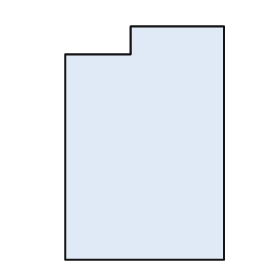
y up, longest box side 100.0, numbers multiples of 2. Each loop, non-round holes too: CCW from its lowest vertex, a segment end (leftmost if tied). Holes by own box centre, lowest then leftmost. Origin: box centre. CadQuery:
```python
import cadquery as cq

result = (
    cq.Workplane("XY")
    .moveTo(-34.0, -50.0)
    .lineTo(34.0, -50.0)
    .lineTo(34.0, 50.0)
    .lineTo(-6.0, 50.0)
    .lineTo(-6.0, 38.0)
    .lineTo(-34.0, 38.0)
    .close()
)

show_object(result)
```